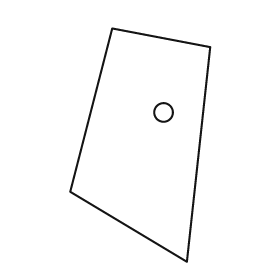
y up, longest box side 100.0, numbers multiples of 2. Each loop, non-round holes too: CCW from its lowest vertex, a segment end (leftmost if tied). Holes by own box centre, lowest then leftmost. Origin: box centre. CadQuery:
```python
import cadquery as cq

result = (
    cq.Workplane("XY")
    .moveTo(20.0, -50.0)
    .lineTo(30.0, 42.0)
    .lineTo(-12.0, 50.0)
    .lineTo(-30.0, -20.0)
    .close()
    .moveTo(10.0, 14.0)
    .circle(4.0)
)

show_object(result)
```